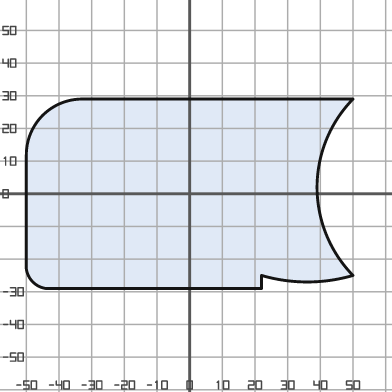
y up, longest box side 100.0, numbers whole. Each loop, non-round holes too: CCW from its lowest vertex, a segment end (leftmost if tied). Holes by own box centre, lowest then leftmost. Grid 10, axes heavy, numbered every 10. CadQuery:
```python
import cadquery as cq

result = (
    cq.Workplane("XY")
    .moveTo(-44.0, -29.0)
    .lineTo(22.0, -29.0)
    .lineTo(22.0, -25.0)
    .threePointArc((36.0, -27.0), (50.0, -25.0))
    .threePointArc((39.0, 2.0), (50.0, 29.0))
    .lineTo(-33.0, 29.0)
    .threePointArc((-45.0, 24.0), (-50.0, 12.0))
    .lineTo(-50.0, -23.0)
    .threePointArc((-48.0, -27.0), (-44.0, -29.0))
    .close()
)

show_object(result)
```